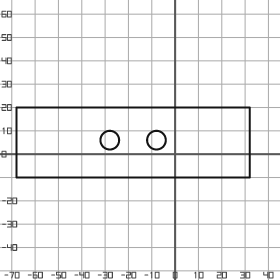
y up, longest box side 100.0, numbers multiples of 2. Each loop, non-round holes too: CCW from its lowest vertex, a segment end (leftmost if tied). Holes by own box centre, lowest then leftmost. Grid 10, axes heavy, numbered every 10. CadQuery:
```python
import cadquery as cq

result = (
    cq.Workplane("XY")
    .moveTo(-68.0, -10.0)
    .lineTo(32.0, -10.0)
    .lineTo(32.0, 20.0)
    .lineTo(-68.0, 20.0)
    .close()
    .moveTo(-28.0, 6.0)
    .circle(4.0)
    .moveTo(-8.0, 6.0)
    .circle(4.0)
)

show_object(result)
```